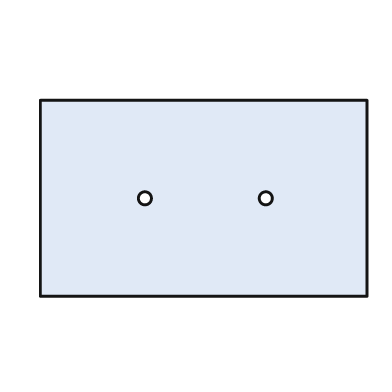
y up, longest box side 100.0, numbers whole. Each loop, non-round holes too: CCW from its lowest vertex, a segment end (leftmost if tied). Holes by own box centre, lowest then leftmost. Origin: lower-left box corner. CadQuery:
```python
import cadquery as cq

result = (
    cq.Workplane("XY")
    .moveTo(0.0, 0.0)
    .lineTo(100.0, 0.0)
    .lineTo(100.0, 60.0)
    .lineTo(0.0, 60.0)
    .close()
    .moveTo(32.0, 30.0)
    .circle(2.0)
    .moveTo(69.0, 30.0)
    .circle(2.0)
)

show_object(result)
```